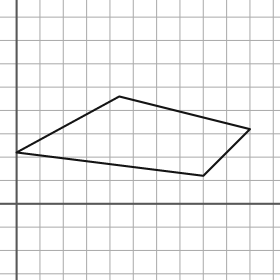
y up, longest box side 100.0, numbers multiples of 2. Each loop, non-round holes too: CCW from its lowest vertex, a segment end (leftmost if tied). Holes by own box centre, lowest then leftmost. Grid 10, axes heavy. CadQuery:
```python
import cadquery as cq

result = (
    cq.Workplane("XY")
    .moveTo(80.0, 12.0)
    .lineTo(100.0, 32.0)
    .lineTo(44.0, 46.0)
    .lineTo(0.0, 22.0)
    .close()
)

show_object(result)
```